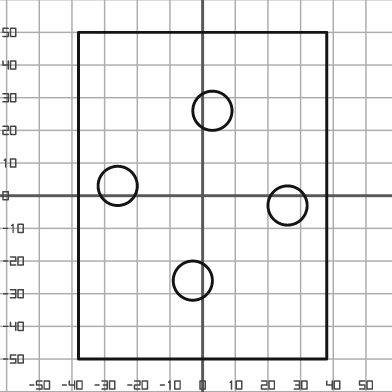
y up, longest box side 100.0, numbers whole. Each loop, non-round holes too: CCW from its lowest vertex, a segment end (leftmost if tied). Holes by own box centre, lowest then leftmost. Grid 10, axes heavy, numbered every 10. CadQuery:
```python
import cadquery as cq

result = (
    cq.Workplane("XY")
    .moveTo(-38.0, -50.0)
    .lineTo(38.0, -50.0)
    .lineTo(38.0, 50.0)
    .lineTo(-38.0, 50.0)
    .close()
    .moveTo(-3.0, -26.0)
    .circle(6.0)
    .moveTo(26.0, -3.0)
    .circle(6.0)
    .moveTo(-26.0, 3.0)
    .circle(6.0)
    .moveTo(3.0, 26.0)
    .circle(6.0)
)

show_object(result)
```